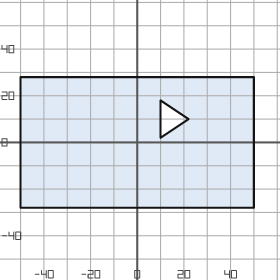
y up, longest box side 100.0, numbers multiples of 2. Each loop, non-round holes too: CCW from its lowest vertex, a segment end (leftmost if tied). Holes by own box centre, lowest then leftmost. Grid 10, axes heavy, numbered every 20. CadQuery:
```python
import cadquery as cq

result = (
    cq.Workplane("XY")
    .moveTo(-50.0, -28.0)
    .lineTo(50.0, -28.0)
    .lineTo(50.0, 28.0)
    .lineTo(-50.0, 28.0)
    .close()
    .moveTo(10.0, 2.0)
    .lineTo(22.0, 10.0)
    .lineTo(10.0, 18.0)
    .close()
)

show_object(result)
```